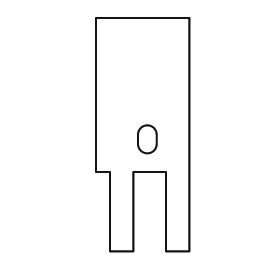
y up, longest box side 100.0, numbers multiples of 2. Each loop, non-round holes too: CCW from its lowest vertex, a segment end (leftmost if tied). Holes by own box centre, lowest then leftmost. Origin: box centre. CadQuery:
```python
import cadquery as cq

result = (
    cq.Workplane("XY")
    .moveTo(-14.0, -50.0)
    .lineTo(-4.0, -50.0)
    .lineTo(-4.0, -16.0)
    .lineTo(10.0, -16.0)
    .lineTo(10.0, -50.0)
    .lineTo(20.0, -50.0)
    .lineTo(20.0, 50.0)
    .lineTo(-20.0, 50.0)
    .lineTo(-20.0, -16.0)
    .lineTo(-14.0, -16.0)
    .close()
    .moveTo(-2.0, -4.0)
    .threePointArc((2.0, -8.0), (6.0, -4.0))
    .lineTo(6.0, 0.0)
    .threePointArc((2.0, 4.0), (-2.0, 0.0))
    .close()
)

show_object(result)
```